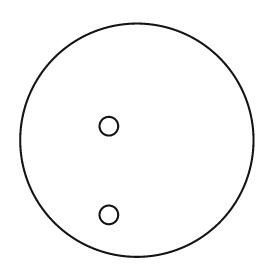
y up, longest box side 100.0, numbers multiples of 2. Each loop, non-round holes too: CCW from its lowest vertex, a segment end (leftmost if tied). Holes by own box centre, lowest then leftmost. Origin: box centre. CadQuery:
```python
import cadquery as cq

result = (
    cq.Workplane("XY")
    .moveTo(0.0, 0.0)
    .circle(50.0)
    .moveTo(-12.0, -32.0)
    .circle(4.0)
    .moveTo(-12.0, 6.0)
    .circle(4.0)
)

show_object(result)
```